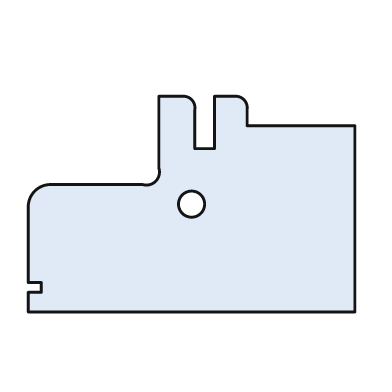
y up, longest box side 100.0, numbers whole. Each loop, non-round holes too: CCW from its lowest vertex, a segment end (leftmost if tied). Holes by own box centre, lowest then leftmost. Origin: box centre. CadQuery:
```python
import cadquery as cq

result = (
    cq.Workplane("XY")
    .moveTo(-50.0, -33.0)
    .lineTo(50.0, -33.0)
    .lineTo(50.0, 24.0)
    .lineTo(17.0, 24.0)
    .lineTo(17.0, 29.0)
    .threePointArc((16.0, 32.0), (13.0, 33.0))
    .lineTo(7.0, 33.0)
    .lineTo(7.0, 17.0)
    .lineTo(1.0, 17.0)
    .lineTo(1.0, 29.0)
    .threePointArc((0.0, 32.0), (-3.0, 33.0))
    .lineTo(-10.0, 33.0)
    .lineTo(-10.0, 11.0)
    .threePointArc((-11.0, 7.0), (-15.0, 6.0))
    .lineTo(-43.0, 6.0)
    .threePointArc((-48.0, 4.0), (-50.0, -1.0))
    .lineTo(-50.0, -24.0)
    .lineTo(-46.0, -24.0)
    .lineTo(-46.0, -27.0)
    .lineTo(-50.0, -27.0)
    .close()
    .moveTo(0.0, 0.0)
    .circle(4.0)
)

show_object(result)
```